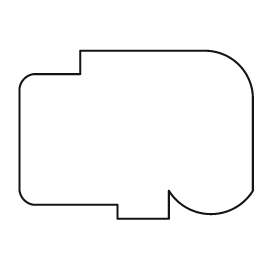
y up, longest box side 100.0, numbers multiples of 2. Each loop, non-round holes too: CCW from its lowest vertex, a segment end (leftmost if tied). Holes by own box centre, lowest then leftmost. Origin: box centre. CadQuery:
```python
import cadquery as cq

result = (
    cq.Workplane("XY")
    .moveTo(-8.0, -36.0)
    .lineTo(14.0, -36.0)
    .lineTo(14.0, -24.0)
    .threePointArc((32.0, -34.0), (50.0, -24.0))
    .lineTo(50.0, 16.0)
    .threePointArc((44.0, 30.0), (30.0, 36.0))
    .lineTo(-24.0, 36.0)
    .lineTo(-24.0, 26.0)
    .lineTo(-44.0, 26.0)
    .threePointArc((-48.0, 24.0), (-50.0, 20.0))
    .lineTo(-50.0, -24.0)
    .threePointArc((-48.0, -28.0), (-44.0, -30.0))
    .lineTo(-8.0, -30.0)
    .close()
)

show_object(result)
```